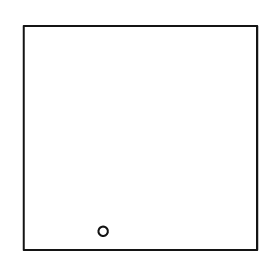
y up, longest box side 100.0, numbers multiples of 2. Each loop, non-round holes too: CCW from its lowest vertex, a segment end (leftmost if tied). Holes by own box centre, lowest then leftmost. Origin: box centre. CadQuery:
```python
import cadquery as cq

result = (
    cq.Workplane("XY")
    .moveTo(-50.0, -48.0)
    .lineTo(50.0, -48.0)
    .lineTo(50.0, 48.0)
    .lineTo(-50.0, 48.0)
    .close()
    .moveTo(-16.0, -40.0)
    .circle(2.0)
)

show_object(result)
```